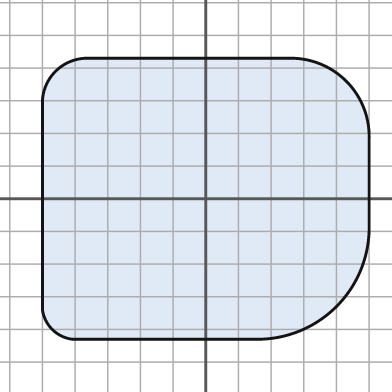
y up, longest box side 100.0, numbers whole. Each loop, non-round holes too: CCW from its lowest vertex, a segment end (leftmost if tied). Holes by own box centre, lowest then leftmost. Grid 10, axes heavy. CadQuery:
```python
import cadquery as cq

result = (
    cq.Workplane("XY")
    .moveTo(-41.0, -43.0)
    .lineTo(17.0, -43.0)
    .threePointArc((40.0, -33.0), (50.0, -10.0))
    .lineTo(50.0, 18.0)
    .threePointArc((43.0, 36.0), (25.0, 43.0))
    .lineTo(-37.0, 43.0)
    .threePointArc((-46.0, 39.0), (-50.0, 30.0))
    .lineTo(-50.0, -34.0)
    .threePointArc((-47.0, -40.0), (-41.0, -43.0))
    .close()
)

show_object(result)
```